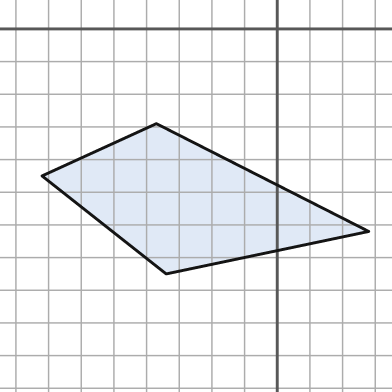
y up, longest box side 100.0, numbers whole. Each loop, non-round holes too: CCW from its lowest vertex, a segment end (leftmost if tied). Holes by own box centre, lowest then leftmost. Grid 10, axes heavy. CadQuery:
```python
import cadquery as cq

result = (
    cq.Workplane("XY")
    .moveTo(-34.0, -75.0)
    .lineTo(28.0, -62.0)
    .lineTo(-37.0, -29.0)
    .lineTo(-72.0, -45.0)
    .close()
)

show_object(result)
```